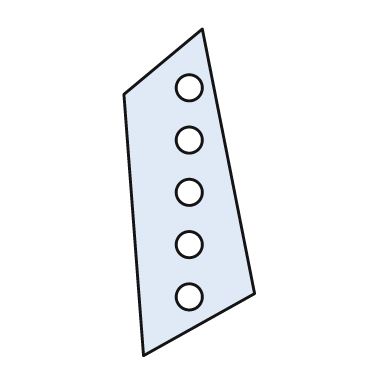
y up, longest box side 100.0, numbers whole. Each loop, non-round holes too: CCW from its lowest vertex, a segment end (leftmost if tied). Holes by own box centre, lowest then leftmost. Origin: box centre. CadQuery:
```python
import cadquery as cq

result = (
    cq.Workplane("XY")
    .moveTo(-14.0, -50.0)
    .lineTo(20.0, -31.0)
    .lineTo(4.0, 50.0)
    .lineTo(-20.0, 30.0)
    .close()
    .moveTo(0.0, -32.0)
    .circle(4.0)
    .moveTo(0.0, -16.0)
    .circle(4.0)
    .moveTo(0.0, 0.0)
    .circle(4.0)
    .moveTo(0.0, 16.0)
    .circle(4.0)
    .moveTo(0.0, 32.0)
    .circle(4.0)
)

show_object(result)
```